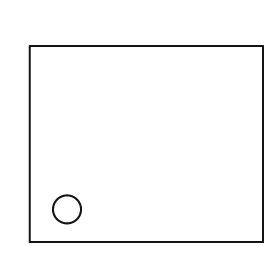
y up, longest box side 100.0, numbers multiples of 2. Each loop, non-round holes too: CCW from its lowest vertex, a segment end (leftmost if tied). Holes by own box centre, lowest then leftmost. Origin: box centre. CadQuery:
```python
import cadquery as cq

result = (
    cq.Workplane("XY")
    .moveTo(-50.0, -42.0)
    .lineTo(50.0, -42.0)
    .lineTo(50.0, 42.0)
    .lineTo(-50.0, 42.0)
    .close()
    .moveTo(-34.0, -28.0)
    .circle(6.0)
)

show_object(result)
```